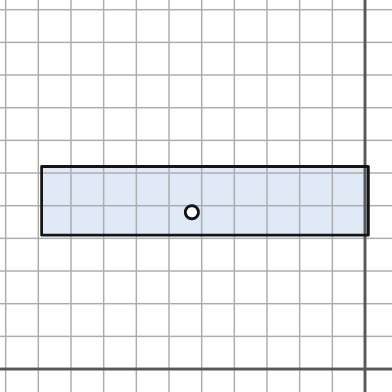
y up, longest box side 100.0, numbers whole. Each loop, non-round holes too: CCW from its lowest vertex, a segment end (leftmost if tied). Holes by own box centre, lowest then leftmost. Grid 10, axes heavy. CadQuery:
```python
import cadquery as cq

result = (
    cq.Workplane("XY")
    .moveTo(-99.0, 41.0)
    .lineTo(1.0, 41.0)
    .lineTo(1.0, 62.0)
    .lineTo(-99.0, 62.0)
    .close()
    .moveTo(-53.0, 48.0)
    .circle(2.0)
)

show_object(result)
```